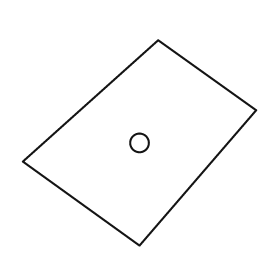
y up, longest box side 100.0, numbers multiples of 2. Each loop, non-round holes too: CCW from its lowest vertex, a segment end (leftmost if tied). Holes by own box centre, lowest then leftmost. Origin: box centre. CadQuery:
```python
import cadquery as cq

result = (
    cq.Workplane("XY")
    .moveTo(0.0, -44.0)
    .lineTo(50.0, 14.0)
    .lineTo(8.0, 44.0)
    .lineTo(-50.0, -8.0)
    .close()
    .moveTo(0.0, 0.0)
    .circle(4.0)
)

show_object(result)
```